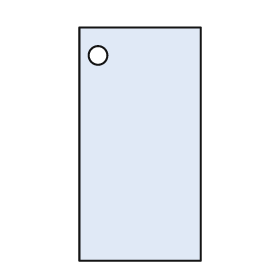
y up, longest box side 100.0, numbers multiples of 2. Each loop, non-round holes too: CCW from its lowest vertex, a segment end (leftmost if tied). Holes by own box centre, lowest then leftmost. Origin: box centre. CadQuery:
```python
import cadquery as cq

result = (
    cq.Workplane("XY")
    .moveTo(-26.0, -50.0)
    .lineTo(26.0, -50.0)
    .lineTo(26.0, 50.0)
    .lineTo(-26.0, 50.0)
    .close()
    .moveTo(-18.0, 38.0)
    .circle(4.0)
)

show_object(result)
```